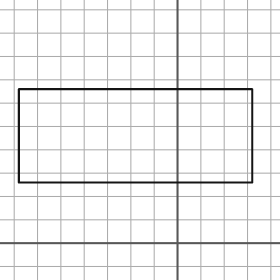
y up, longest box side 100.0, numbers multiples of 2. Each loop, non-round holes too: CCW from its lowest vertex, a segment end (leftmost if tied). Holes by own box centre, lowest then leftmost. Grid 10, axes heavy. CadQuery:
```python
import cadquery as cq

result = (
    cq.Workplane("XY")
    .moveTo(-68.0, 26.0)
    .lineTo(32.0, 26.0)
    .lineTo(32.0, 66.0)
    .lineTo(-68.0, 66.0)
    .close()
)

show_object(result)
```